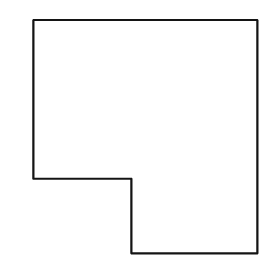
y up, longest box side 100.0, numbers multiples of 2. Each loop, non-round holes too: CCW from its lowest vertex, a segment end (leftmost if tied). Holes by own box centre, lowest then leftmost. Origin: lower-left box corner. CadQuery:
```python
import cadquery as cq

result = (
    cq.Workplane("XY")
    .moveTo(42.0, 0.0)
    .lineTo(96.0, 0.0)
    .lineTo(96.0, 100.0)
    .lineTo(0.0, 100.0)
    .lineTo(0.0, 32.0)
    .lineTo(42.0, 32.0)
    .close()
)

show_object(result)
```